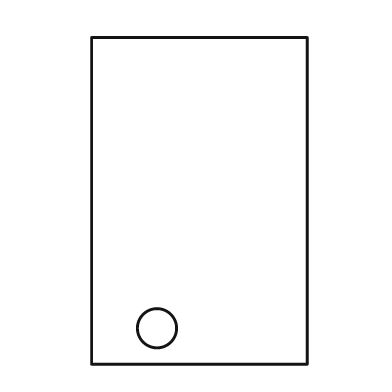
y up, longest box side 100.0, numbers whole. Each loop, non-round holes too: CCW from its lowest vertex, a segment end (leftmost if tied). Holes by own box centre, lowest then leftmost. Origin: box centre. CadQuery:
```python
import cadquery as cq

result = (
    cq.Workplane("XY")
    .moveTo(-33.0, -50.0)
    .lineTo(33.0, -50.0)
    .lineTo(33.0, 50.0)
    .lineTo(-33.0, 50.0)
    .close()
    .moveTo(-13.0, -39.0)
    .circle(6.0)
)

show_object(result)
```